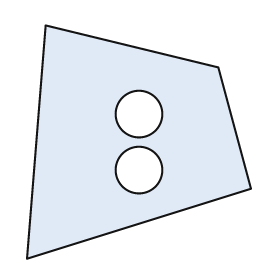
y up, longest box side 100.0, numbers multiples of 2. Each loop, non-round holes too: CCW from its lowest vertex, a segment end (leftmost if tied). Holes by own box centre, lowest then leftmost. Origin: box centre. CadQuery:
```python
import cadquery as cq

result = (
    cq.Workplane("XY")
    .moveTo(-48.0, -50.0)
    .lineTo(48.0, -20.0)
    .lineTo(34.0, 32.0)
    .lineTo(-40.0, 50.0)
    .close()
    .moveTo(0.0, -12.0)
    .circle(10.0)
    .moveTo(0.0, 12.0)
    .circle(10.0)
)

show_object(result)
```